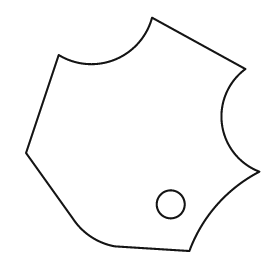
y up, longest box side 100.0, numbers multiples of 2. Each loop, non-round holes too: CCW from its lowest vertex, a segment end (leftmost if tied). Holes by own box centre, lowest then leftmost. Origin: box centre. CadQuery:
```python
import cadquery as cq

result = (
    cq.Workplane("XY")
    .moveTo(20.0, -50.0)
    .threePointArc((32.0, -30.0), (50.0, -16.0))
    .threePointArc((34.0, 4.0), (44.0, 28.0))
    .lineTo(4.0, 50.0)
    .threePointArc((-12.0, 32.0), (-36.0, 34.0))
    .lineTo(-50.0, -8.0)
    .lineTo(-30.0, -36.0)
    .threePointArc((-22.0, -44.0), (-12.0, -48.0))
    .close()
    .moveTo(12.0, -30.0)
    .circle(6.0)
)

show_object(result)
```